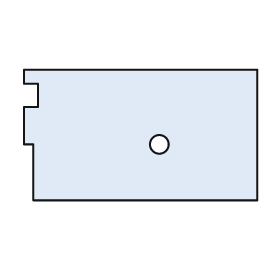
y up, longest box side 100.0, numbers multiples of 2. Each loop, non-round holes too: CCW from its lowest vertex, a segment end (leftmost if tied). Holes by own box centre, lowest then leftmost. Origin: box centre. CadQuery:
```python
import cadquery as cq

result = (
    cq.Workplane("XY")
    .moveTo(-46.0, -28.0)
    .lineTo(50.0, -28.0)
    .lineTo(50.0, 28.0)
    .lineTo(-50.0, 28.0)
    .lineTo(-50.0, 22.0)
    .lineTo(-44.0, 22.0)
    .lineTo(-44.0, 12.0)
    .lineTo(-50.0, 12.0)
    .lineTo(-50.0, -4.0)
    .lineTo(-46.0, -4.0)
    .close()
    .moveTo(8.0, -4.0)
    .circle(4.0)
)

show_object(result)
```